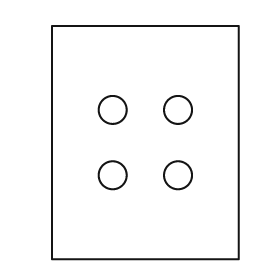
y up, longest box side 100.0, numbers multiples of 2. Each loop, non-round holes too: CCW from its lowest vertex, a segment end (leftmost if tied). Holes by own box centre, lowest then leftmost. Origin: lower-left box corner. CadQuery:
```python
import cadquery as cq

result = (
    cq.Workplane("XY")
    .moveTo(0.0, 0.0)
    .lineTo(80.0, 0.0)
    .lineTo(80.0, 100.0)
    .lineTo(0.0, 100.0)
    .close()
    .moveTo(26.0, 36.0)
    .circle(6.0)
    .moveTo(54.0, 36.0)
    .circle(6.0)
    .moveTo(26.0, 64.0)
    .circle(6.0)
    .moveTo(54.0, 64.0)
    .circle(6.0)
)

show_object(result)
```